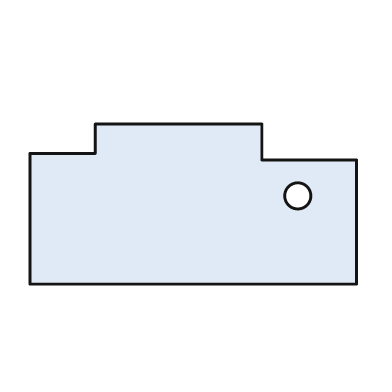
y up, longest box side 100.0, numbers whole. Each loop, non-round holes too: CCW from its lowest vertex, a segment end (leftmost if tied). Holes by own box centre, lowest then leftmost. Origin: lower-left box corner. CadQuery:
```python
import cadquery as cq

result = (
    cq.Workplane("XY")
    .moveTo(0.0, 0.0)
    .lineTo(100.0, 0.0)
    .lineTo(100.0, 38.0)
    .lineTo(71.0, 38.0)
    .lineTo(71.0, 49.0)
    .lineTo(20.0, 49.0)
    .lineTo(20.0, 40.0)
    .lineTo(0.0, 40.0)
    .close()
    .moveTo(82.0, 27.0)
    .circle(4.0)
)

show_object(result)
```